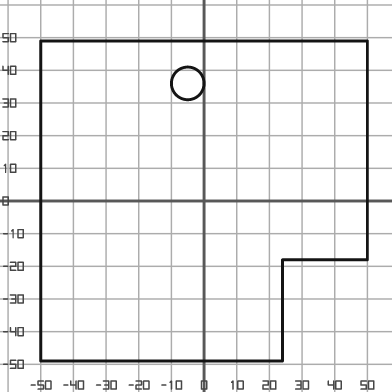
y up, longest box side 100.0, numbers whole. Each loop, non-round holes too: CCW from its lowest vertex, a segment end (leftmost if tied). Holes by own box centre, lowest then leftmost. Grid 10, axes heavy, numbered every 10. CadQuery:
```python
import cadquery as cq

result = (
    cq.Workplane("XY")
    .moveTo(-50.0, -49.0)
    .lineTo(24.0, -49.0)
    .lineTo(24.0, -18.0)
    .lineTo(50.0, -18.0)
    .lineTo(50.0, 49.0)
    .lineTo(-50.0, 49.0)
    .close()
    .moveTo(-5.0, 36.0)
    .circle(5.0)
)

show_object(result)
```